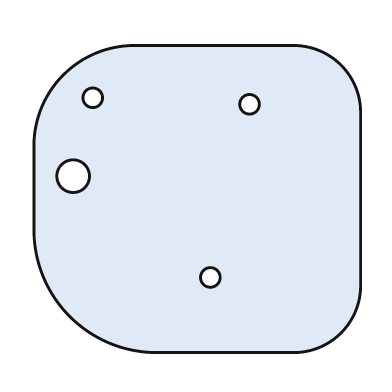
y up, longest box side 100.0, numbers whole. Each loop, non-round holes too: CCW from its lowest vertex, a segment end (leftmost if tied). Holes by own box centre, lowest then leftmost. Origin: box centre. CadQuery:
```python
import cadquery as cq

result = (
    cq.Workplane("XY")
    .moveTo(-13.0, -47.0)
    .lineTo(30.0, -47.0)
    .threePointArc((44.0, -41.0), (50.0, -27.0))
    .lineTo(50.0, 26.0)
    .threePointArc((44.0, 41.0), (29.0, 47.0))
    .lineTo(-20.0, 47.0)
    .threePointArc((-41.0, 38.0), (-50.0, 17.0))
    .lineTo(-50.0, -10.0)
    .threePointArc((-39.0, -36.0), (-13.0, -47.0))
    .close()
    .moveTo(4.0, -24.0)
    .circle(3.0)
    .moveTo(-38.0, 7.0)
    .circle(5.0)
    .moveTo(16.0, 29.0)
    .circle(3.0)
    .moveTo(-32.0, 31.0)
    .circle(3.0)
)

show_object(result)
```